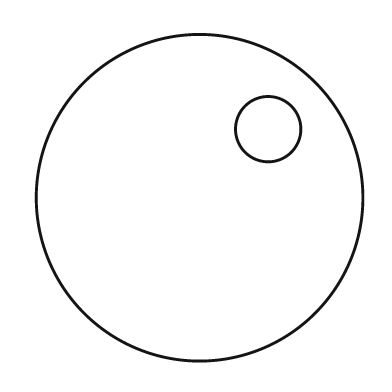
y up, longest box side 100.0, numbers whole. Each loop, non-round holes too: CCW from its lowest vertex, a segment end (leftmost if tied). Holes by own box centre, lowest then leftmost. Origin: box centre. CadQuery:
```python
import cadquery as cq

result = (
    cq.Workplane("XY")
    .moveTo(0.0, 0.0)
    .circle(50.0)
    .moveTo(21.0, 21.0)
    .circle(10.0)
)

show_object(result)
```